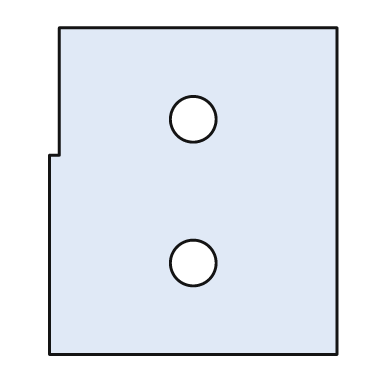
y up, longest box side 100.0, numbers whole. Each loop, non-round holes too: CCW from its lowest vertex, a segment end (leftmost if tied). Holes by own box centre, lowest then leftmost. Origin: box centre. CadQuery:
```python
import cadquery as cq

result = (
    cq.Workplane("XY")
    .moveTo(-44.0, -50.0)
    .lineTo(44.0, -50.0)
    .lineTo(44.0, 50.0)
    .lineTo(-41.0, 50.0)
    .lineTo(-41.0, 11.0)
    .lineTo(-44.0, 11.0)
    .close()
    .moveTo(0.0, -22.0)
    .circle(7.0)
    .moveTo(0.0, 22.0)
    .circle(7.0)
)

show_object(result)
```